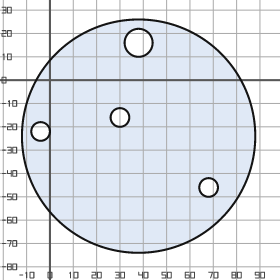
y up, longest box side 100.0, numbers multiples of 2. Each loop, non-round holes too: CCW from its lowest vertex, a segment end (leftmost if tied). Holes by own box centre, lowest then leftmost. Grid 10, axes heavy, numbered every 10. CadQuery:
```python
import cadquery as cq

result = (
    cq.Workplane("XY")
    .moveTo(38.0, -24.0)
    .circle(50.0)
    .moveTo(68.0, -46.0)
    .circle(4.0)
    .moveTo(-4.0, -22.0)
    .circle(4.0)
    .moveTo(30.0, -16.0)
    .circle(4.0)
    .moveTo(38.0, 16.0)
    .circle(6.0)
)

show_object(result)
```